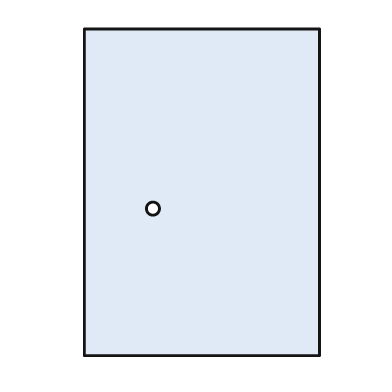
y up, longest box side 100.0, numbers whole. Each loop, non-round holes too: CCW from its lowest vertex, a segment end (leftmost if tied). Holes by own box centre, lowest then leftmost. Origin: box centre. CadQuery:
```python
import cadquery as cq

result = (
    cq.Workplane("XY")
    .moveTo(-36.0, -50.0)
    .lineTo(36.0, -50.0)
    .lineTo(36.0, 50.0)
    .lineTo(-36.0, 50.0)
    .close()
    .moveTo(-15.0, -5.0)
    .circle(2.0)
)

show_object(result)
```